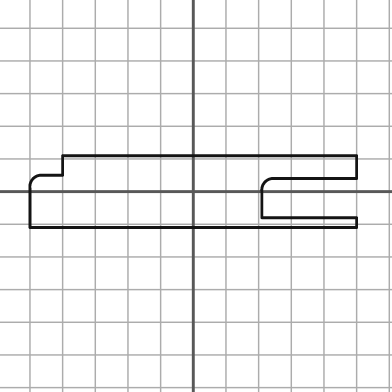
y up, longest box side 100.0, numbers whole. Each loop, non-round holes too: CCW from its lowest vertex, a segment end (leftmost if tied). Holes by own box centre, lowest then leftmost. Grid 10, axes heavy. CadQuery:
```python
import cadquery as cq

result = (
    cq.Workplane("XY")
    .moveTo(-50.0, -11.0)
    .lineTo(50.0, -11.0)
    .lineTo(50.0, -8.0)
    .lineTo(21.0, -8.0)
    .lineTo(21.0, 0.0)
    .threePointArc((22.0, 3.0), (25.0, 4.0))
    .lineTo(50.0, 4.0)
    .lineTo(50.0, 11.0)
    .lineTo(-40.0, 11.0)
    .lineTo(-40.0, 5.0)
    .lineTo(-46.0, 5.0)
    .threePointArc((-49.0, 4.0), (-50.0, 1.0))
    .close()
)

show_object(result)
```